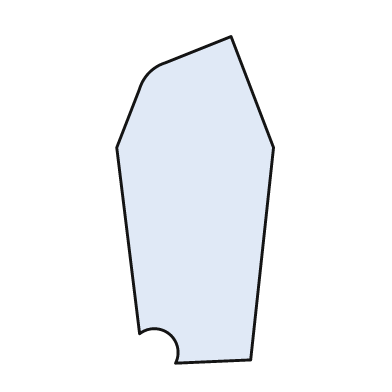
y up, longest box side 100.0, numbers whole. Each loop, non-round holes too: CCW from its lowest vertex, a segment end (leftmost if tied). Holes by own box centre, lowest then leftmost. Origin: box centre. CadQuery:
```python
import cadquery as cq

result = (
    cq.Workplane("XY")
    .moveTo(-6.0, -50.0)
    .lineTo(17.0, -49.0)
    .lineTo(24.0, 16.0)
    .lineTo(11.0, 50.0)
    .lineTo(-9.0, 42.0)
    .threePointArc((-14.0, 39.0), (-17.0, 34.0))
    .lineTo(-24.0, 16.0)
    .lineTo(-17.0, -41.0)
    .threePointArc((-8.0, -41.0), (-6.0, -50.0))
    .close()
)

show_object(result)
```